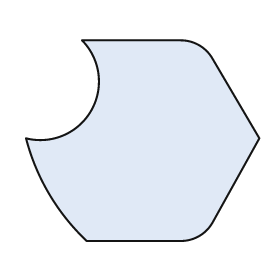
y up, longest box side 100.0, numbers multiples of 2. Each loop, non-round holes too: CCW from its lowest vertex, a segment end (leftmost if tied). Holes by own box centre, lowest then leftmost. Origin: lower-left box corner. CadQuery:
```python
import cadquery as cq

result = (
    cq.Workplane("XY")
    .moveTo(26.0, 0.0)
    .lineTo(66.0, 0.0)
    .threePointArc((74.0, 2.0), (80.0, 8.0))
    .lineTo(100.0, 44.0)
    .lineTo(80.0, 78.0)
    .threePointArc((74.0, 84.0), (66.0, 86.0))
    .lineTo(24.0, 86.0)
    .threePointArc((28.0, 56.0), (0.0, 44.0))
    .threePointArc((10.0, 20.0), (26.0, 0.0))
    .close()
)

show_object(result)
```